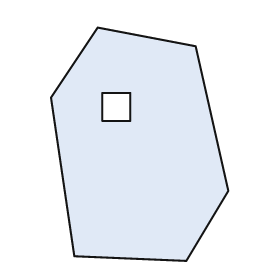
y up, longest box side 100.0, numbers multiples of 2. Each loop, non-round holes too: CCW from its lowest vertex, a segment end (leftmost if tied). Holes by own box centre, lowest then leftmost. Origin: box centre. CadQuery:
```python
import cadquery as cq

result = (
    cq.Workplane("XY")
    .moveTo(20.0, -50.0)
    .lineTo(38.0, -20.0)
    .lineTo(24.0, 42.0)
    .lineTo(-18.0, 50.0)
    .lineTo(-38.0, 20.0)
    .lineTo(-28.0, -48.0)
    .close()
    .moveTo(-16.0, 10.0)
    .lineTo(-4.0, 10.0)
    .lineTo(-4.0, 22.0)
    .lineTo(-16.0, 22.0)
    .close()
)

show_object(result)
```